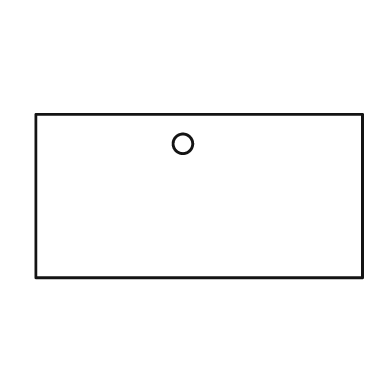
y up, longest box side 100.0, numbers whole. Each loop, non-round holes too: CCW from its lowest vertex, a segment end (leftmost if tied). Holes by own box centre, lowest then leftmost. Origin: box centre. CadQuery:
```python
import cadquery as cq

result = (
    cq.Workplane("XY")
    .moveTo(-50.0, -25.0)
    .lineTo(50.0, -25.0)
    .lineTo(50.0, 25.0)
    .lineTo(-50.0, 25.0)
    .close()
    .moveTo(-5.0, 16.0)
    .circle(3.0)
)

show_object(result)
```